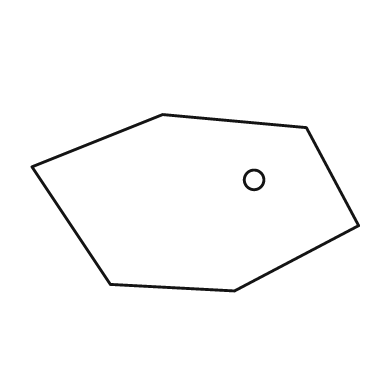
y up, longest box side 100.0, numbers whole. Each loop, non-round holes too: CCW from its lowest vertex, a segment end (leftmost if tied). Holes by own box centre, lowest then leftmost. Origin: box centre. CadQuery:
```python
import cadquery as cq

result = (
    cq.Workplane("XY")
    .moveTo(12.0, -27.0)
    .lineTo(50.0, -7.0)
    .lineTo(34.0, 23.0)
    .lineTo(-10.0, 27.0)
    .lineTo(-50.0, 11.0)
    .lineTo(-26.0, -25.0)
    .close()
    .moveTo(18.0, 7.0)
    .circle(3.0)
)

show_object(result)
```